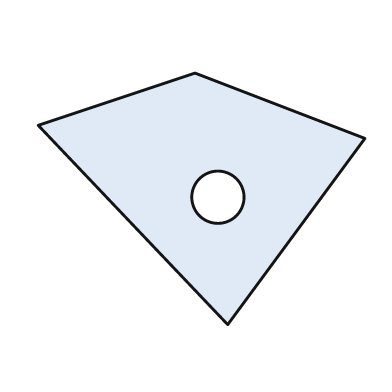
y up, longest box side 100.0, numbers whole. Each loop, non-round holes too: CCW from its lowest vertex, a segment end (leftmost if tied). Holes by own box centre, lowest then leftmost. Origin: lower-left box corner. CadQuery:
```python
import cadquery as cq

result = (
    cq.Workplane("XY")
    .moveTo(58.0, 0.0)
    .lineTo(100.0, 57.0)
    .lineTo(48.0, 77.0)
    .lineTo(0.0, 61.0)
    .close()
    .moveTo(55.0, 39.0)
    .circle(8.0)
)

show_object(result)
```